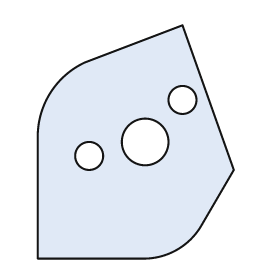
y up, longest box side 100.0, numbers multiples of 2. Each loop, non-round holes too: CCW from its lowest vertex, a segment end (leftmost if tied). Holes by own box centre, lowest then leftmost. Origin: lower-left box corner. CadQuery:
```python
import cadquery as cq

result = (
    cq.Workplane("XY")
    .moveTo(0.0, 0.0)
    .lineTo(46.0, 0.0)
    .threePointArc((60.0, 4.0), (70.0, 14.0))
    .lineTo(84.0, 38.0)
    .lineTo(62.0, 100.0)
    .lineTo(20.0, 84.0)
    .threePointArc((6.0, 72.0), (0.0, 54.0))
    .close()
    .moveTo(22.0, 44.0)
    .circle(6.0)
    .moveTo(46.0, 50.0)
    .circle(10.0)
    .moveTo(62.0, 68.0)
    .circle(6.0)
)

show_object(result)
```